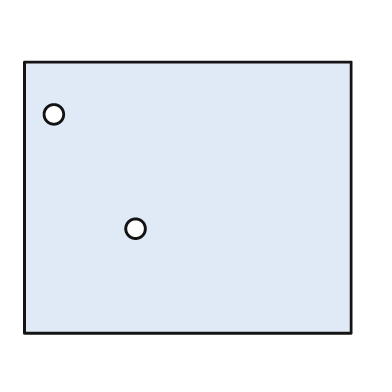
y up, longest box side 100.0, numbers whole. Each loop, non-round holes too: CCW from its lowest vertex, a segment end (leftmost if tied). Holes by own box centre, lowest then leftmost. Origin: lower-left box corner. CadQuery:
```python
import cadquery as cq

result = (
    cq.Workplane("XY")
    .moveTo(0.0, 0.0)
    .lineTo(100.0, 0.0)
    .lineTo(100.0, 83.0)
    .lineTo(0.0, 83.0)
    .close()
    .moveTo(34.0, 32.0)
    .circle(3.0)
    .moveTo(9.0, 67.0)
    .circle(3.0)
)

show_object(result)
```